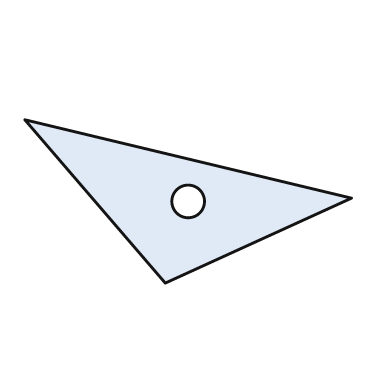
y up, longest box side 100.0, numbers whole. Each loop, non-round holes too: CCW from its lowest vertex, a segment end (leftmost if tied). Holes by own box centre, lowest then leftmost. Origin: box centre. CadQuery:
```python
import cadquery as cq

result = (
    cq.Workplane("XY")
    .moveTo(-7.0, -25.0)
    .lineTo(50.0, 1.0)
    .lineTo(-50.0, 25.0)
    .close()
    .moveTo(0.0, 0.0)
    .circle(5.0)
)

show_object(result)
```